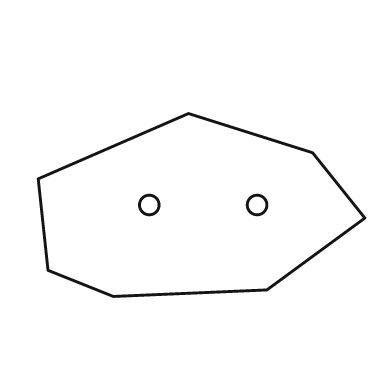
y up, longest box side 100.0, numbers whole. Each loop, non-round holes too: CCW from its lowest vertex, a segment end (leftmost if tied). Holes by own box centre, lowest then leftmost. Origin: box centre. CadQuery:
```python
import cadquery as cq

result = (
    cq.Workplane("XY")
    .moveTo(-27.0, -28.0)
    .lineTo(20.0, -26.0)
    .lineTo(50.0, -4.0)
    .lineTo(34.0, 16.0)
    .lineTo(-4.0, 28.0)
    .lineTo(-50.0, 8.0)
    .lineTo(-47.0, -20.0)
    .close()
    .moveTo(-16.0, 0.0)
    .circle(3.0)
    .moveTo(17.0, 0.0)
    .circle(3.0)
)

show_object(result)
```